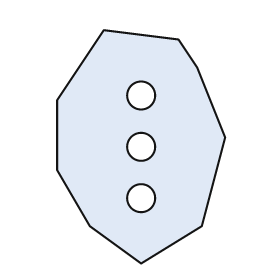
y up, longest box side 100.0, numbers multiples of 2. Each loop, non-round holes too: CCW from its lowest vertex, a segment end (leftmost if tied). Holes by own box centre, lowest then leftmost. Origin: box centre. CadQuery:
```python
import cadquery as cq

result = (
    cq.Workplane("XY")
    .moveTo(0.0, -50.0)
    .lineTo(26.0, -34.0)
    .lineTo(36.0, 4.0)
    .lineTo(24.0, 34.0)
    .lineTo(16.0, 46.0)
    .lineTo(-16.0, 50.0)
    .lineTo(-36.0, 20.0)
    .lineTo(-36.0, -10.0)
    .lineTo(-22.0, -34.0)
    .close()
    .moveTo(0.0, -22.0)
    .circle(6.0)
    .moveTo(0.0, 0.0)
    .circle(6.0)
    .moveTo(0.0, 22.0)
    .circle(6.0)
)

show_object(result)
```